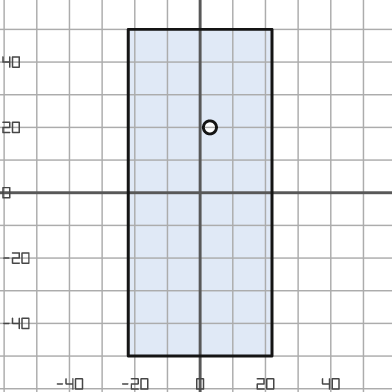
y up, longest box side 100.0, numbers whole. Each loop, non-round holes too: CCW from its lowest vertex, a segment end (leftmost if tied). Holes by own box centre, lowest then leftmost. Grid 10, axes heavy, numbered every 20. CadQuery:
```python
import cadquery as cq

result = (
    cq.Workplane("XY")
    .moveTo(-22.0, -50.0)
    .lineTo(22.0, -50.0)
    .lineTo(22.0, 50.0)
    .lineTo(-22.0, 50.0)
    .close()
    .moveTo(3.0, 20.0)
    .circle(2.0)
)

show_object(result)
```